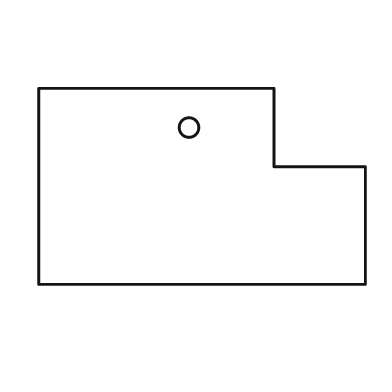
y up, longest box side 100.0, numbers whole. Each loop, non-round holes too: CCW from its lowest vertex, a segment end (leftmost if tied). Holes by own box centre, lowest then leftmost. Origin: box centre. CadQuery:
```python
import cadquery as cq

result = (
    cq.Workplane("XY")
    .moveTo(-50.0, -30.0)
    .lineTo(50.0, -30.0)
    .lineTo(50.0, 6.0)
    .lineTo(22.0, 6.0)
    .lineTo(22.0, 30.0)
    .lineTo(-50.0, 30.0)
    .close()
    .moveTo(-4.0, 18.0)
    .circle(3.0)
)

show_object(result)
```